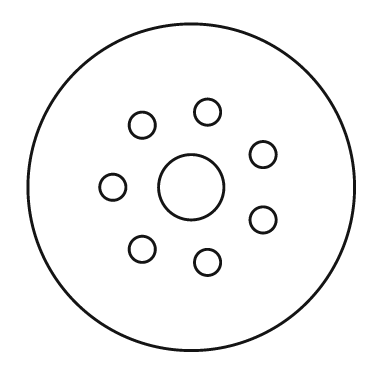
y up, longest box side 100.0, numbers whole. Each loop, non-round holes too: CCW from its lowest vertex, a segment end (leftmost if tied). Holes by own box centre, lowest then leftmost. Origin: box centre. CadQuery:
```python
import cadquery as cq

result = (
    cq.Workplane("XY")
    .moveTo(0.0, 0.0)
    .circle(50.0)
    .moveTo(5.0, -23.0)
    .circle(4.0)
    .moveTo(-15.0, -19.0)
    .circle(4.0)
    .moveTo(22.0, -10.0)
    .circle(4.0)
    .moveTo(-24.0, 0.0)
    .circle(4.0)
    .moveTo(0.0, 0.0)
    .circle(10.0)
    .moveTo(22.0, 10.0)
    .circle(4.0)
    .moveTo(-15.0, 19.0)
    .circle(4.0)
    .moveTo(5.0, 23.0)
    .circle(4.0)
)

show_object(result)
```